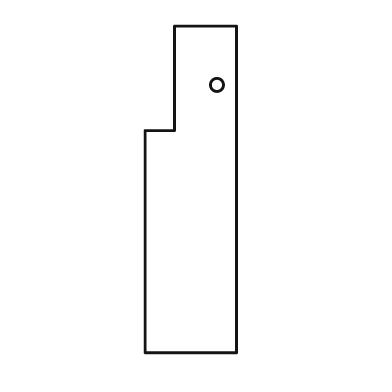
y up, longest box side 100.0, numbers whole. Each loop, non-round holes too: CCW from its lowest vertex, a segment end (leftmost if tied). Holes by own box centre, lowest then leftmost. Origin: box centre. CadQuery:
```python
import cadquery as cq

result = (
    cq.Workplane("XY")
    .moveTo(-14.0, -50.0)
    .lineTo(14.0, -50.0)
    .lineTo(14.0, 50.0)
    .lineTo(-5.0, 50.0)
    .lineTo(-5.0, 18.0)
    .lineTo(-14.0, 18.0)
    .close()
    .moveTo(8.0, 32.0)
    .circle(2.0)
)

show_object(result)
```